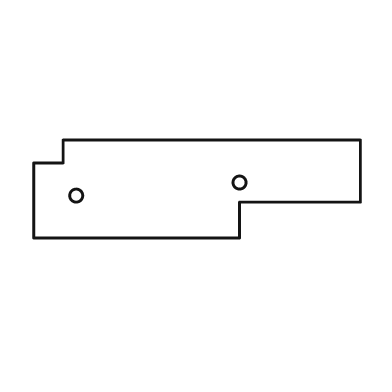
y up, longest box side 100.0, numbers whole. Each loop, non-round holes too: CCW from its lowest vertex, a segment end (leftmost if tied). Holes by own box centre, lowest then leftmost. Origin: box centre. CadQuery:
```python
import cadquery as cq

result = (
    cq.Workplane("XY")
    .moveTo(-50.0, -15.0)
    .lineTo(13.0, -15.0)
    .lineTo(13.0, -4.0)
    .lineTo(50.0, -4.0)
    .lineTo(50.0, 15.0)
    .lineTo(-41.0, 15.0)
    .lineTo(-41.0, 8.0)
    .lineTo(-50.0, 8.0)
    .close()
    .moveTo(-37.0, -2.0)
    .circle(2.0)
    .moveTo(13.0, 2.0)
    .circle(2.0)
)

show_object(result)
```